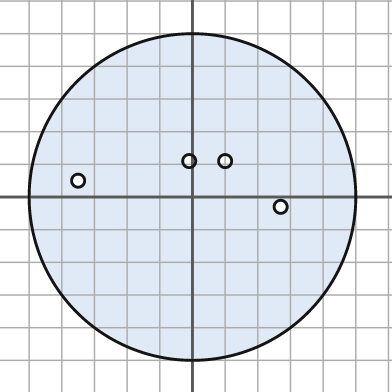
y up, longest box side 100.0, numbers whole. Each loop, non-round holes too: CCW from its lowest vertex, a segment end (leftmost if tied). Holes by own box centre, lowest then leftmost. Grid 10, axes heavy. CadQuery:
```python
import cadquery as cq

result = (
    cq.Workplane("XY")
    .moveTo(0.0, 0.0)
    .circle(50.0)
    .moveTo(27.0, -3.0)
    .circle(2.0)
    .moveTo(-35.0, 5.0)
    .circle(2.0)
    .moveTo(-1.0, 11.0)
    .circle(2.0)
    .moveTo(10.0, 11.0)
    .circle(2.0)
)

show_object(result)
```